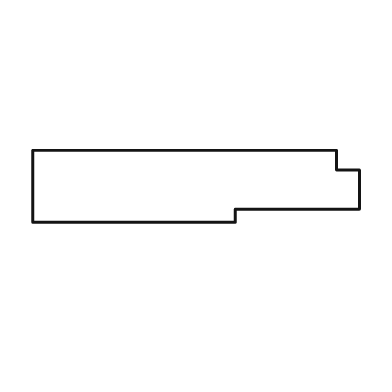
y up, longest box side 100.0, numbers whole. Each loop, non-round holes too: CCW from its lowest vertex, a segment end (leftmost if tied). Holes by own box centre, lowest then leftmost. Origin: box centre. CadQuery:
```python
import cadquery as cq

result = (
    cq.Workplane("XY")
    .moveTo(-50.0, -11.0)
    .lineTo(12.0, -11.0)
    .lineTo(12.0, -7.0)
    .lineTo(50.0, -7.0)
    .lineTo(50.0, 5.0)
    .lineTo(43.0, 5.0)
    .lineTo(43.0, 11.0)
    .lineTo(-50.0, 11.0)
    .close()
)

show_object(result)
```